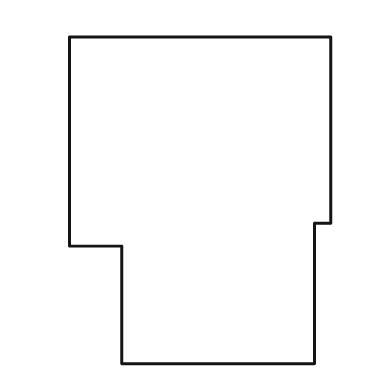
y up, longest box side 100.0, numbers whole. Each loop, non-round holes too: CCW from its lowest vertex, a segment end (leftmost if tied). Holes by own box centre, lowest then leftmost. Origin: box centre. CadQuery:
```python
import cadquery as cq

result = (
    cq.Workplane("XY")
    .moveTo(-24.0, -50.0)
    .lineTo(35.0, -50.0)
    .lineTo(35.0, -7.0)
    .lineTo(40.0, -7.0)
    .lineTo(40.0, 50.0)
    .lineTo(-40.0, 50.0)
    .lineTo(-40.0, -14.0)
    .lineTo(-24.0, -14.0)
    .close()
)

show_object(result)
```